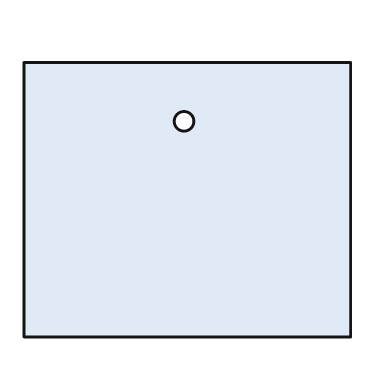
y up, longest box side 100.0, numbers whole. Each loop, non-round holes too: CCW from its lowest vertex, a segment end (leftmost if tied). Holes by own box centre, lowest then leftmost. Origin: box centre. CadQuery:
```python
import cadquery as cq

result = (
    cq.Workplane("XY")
    .moveTo(-50.0, -42.0)
    .lineTo(50.0, -42.0)
    .lineTo(50.0, 42.0)
    .lineTo(-50.0, 42.0)
    .close()
    .moveTo(-1.0, 24.0)
    .circle(3.0)
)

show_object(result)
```